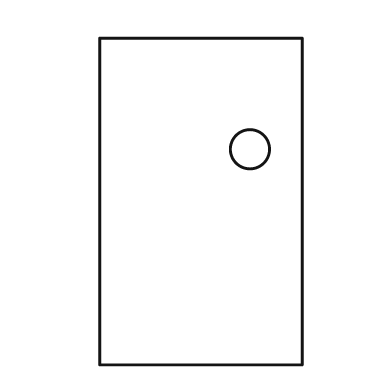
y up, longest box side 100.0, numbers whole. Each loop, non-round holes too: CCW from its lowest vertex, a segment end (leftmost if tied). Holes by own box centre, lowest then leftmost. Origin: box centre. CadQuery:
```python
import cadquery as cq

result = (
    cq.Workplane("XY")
    .moveTo(-31.0, -50.0)
    .lineTo(31.0, -50.0)
    .lineTo(31.0, 50.0)
    .lineTo(-31.0, 50.0)
    .close()
    .moveTo(15.0, 16.0)
    .circle(6.0)
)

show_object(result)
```